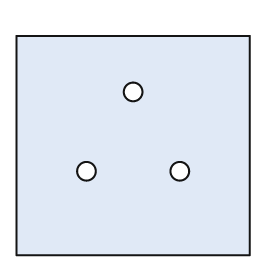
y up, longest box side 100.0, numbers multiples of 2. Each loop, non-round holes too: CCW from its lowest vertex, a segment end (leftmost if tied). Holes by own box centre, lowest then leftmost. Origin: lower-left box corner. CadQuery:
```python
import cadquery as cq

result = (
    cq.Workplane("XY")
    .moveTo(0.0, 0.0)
    .lineTo(100.0, 0.0)
    .lineTo(100.0, 94.0)
    .lineTo(0.0, 94.0)
    .close()
    .moveTo(30.0, 36.0)
    .circle(4.0)
    .moveTo(70.0, 36.0)
    .circle(4.0)
    .moveTo(50.0, 70.0)
    .circle(4.0)
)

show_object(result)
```